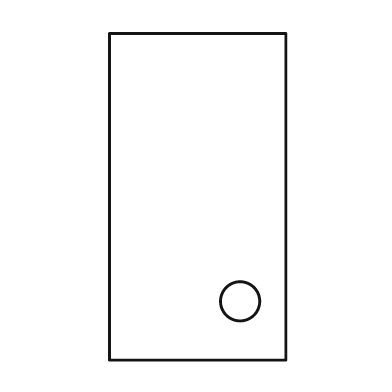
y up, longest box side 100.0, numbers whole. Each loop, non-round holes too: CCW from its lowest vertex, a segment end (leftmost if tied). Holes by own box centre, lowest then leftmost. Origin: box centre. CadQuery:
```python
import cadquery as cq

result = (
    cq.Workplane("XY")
    .moveTo(-27.0, -50.0)
    .lineTo(27.0, -50.0)
    .lineTo(27.0, 50.0)
    .lineTo(-27.0, 50.0)
    .close()
    .moveTo(13.0, -32.0)
    .circle(6.0)
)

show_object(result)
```